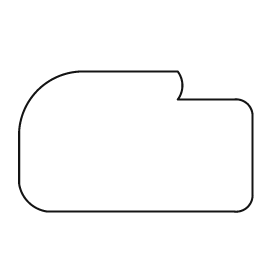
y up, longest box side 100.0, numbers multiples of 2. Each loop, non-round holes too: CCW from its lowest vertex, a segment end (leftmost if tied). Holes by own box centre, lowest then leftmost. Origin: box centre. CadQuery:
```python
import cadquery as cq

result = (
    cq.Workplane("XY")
    .moveTo(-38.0, -30.0)
    .lineTo(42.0, -30.0)
    .threePointArc((48.0, -28.0), (50.0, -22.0))
    .lineTo(50.0, 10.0)
    .threePointArc((48.0, 16.0), (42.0, 18.0))
    .lineTo(18.0, 18.0)
    .threePointArc((20.0, 24.0), (18.0, 30.0))
    .lineTo(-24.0, 30.0)
    .threePointArc((-42.0, 22.0), (-50.0, 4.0))
    .lineTo(-50.0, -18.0)
    .threePointArc((-46.0, -26.0), (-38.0, -30.0))
    .close()
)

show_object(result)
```